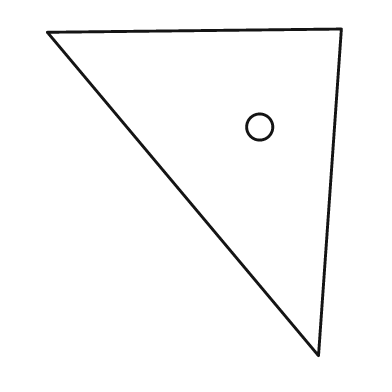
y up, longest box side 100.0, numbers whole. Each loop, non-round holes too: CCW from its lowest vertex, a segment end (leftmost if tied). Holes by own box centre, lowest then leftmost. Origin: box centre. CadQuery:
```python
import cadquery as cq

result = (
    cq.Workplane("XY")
    .moveTo(38.0, -50.0)
    .lineTo(45.0, 50.0)
    .lineTo(-45.0, 49.0)
    .close()
    .moveTo(20.0, 20.0)
    .circle(4.0)
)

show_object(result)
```